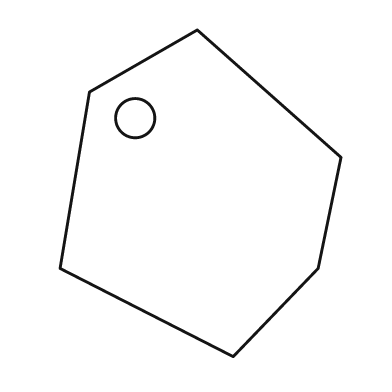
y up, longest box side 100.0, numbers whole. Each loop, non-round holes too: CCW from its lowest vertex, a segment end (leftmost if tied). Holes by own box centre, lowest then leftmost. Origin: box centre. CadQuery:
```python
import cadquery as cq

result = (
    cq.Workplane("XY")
    .moveTo(10.0, -50.0)
    .lineTo(36.0, -23.0)
    .lineTo(43.0, 11.0)
    .lineTo(-1.0, 50.0)
    .lineTo(-34.0, 31.0)
    .lineTo(-43.0, -23.0)
    .close()
    .moveTo(-20.0, 23.0)
    .circle(6.0)
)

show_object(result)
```